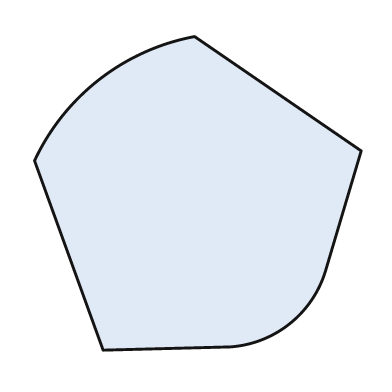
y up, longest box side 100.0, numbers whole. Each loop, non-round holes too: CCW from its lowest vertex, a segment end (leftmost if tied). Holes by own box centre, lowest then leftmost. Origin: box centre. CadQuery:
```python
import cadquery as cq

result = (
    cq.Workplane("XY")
    .moveTo(-29.0, -48.0)
    .lineTo(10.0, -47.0)
    .threePointArc((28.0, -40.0), (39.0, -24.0))
    .lineTo(50.0, 13.0)
    .lineTo(-1.0, 48.0)
    .threePointArc((-30.0, 35.0), (-50.0, 10.0))
    .close()
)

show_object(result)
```